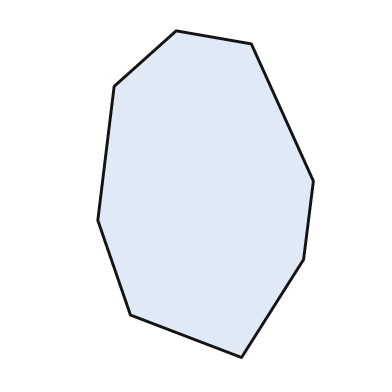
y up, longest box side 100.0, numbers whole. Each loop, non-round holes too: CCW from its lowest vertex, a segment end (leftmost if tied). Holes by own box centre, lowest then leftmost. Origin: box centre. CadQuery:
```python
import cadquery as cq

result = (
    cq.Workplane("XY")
    .moveTo(11.0, -50.0)
    .lineTo(30.0, -20.0)
    .lineTo(33.0, 4.0)
    .lineTo(14.0, 46.0)
    .lineTo(-9.0, 50.0)
    .lineTo(-28.0, 33.0)
    .lineTo(-33.0, -8.0)
    .lineTo(-23.0, -37.0)
    .close()
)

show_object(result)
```